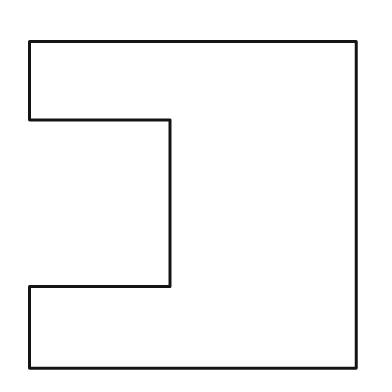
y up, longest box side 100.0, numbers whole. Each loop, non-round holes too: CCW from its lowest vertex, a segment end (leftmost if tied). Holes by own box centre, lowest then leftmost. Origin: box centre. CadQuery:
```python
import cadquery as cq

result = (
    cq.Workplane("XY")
    .moveTo(-50.0, -50.0)
    .lineTo(50.0, -50.0)
    .lineTo(50.0, 50.0)
    .lineTo(-50.0, 50.0)
    .lineTo(-50.0, 26.0)
    .lineTo(-7.0, 26.0)
    .lineTo(-7.0, -25.0)
    .lineTo(-50.0, -25.0)
    .close()
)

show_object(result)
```